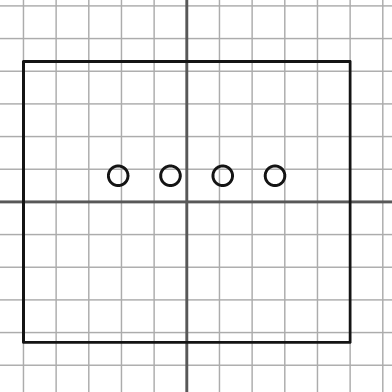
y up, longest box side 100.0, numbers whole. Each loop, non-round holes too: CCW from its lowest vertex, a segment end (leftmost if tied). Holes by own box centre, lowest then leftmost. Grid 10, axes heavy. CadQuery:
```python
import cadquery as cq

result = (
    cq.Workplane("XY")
    .moveTo(-50.0, -43.0)
    .lineTo(50.0, -43.0)
    .lineTo(50.0, 43.0)
    .lineTo(-50.0, 43.0)
    .close()
    .moveTo(-21.0, 8.0)
    .circle(3.0)
    .moveTo(-5.0, 8.0)
    .circle(3.0)
    .moveTo(11.0, 8.0)
    .circle(3.0)
    .moveTo(27.0, 8.0)
    .circle(3.0)
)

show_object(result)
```